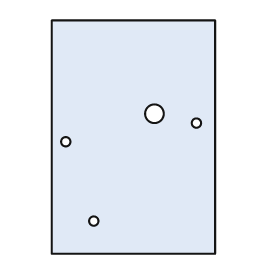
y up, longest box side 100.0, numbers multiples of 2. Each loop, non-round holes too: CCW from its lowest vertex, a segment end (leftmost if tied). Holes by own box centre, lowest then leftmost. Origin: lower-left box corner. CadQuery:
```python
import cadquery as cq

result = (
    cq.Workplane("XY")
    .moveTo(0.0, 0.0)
    .lineTo(70.0, 0.0)
    .lineTo(70.0, 100.0)
    .lineTo(0.0, 100.0)
    .close()
    .moveTo(18.0, 14.0)
    .circle(2.0)
    .moveTo(6.0, 48.0)
    .circle(2.0)
    .moveTo(62.0, 56.0)
    .circle(2.0)
    .moveTo(44.0, 60.0)
    .circle(4.0)
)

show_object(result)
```